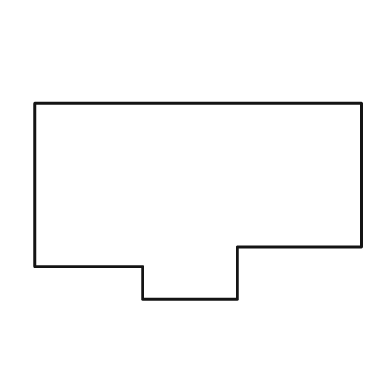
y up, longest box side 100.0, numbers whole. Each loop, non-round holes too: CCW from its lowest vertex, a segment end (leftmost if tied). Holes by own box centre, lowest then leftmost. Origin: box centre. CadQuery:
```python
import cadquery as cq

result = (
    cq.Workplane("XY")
    .moveTo(-17.0, -30.0)
    .lineTo(12.0, -30.0)
    .lineTo(12.0, -14.0)
    .lineTo(50.0, -14.0)
    .lineTo(50.0, 30.0)
    .lineTo(-50.0, 30.0)
    .lineTo(-50.0, -20.0)
    .lineTo(-17.0, -20.0)
    .close()
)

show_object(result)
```